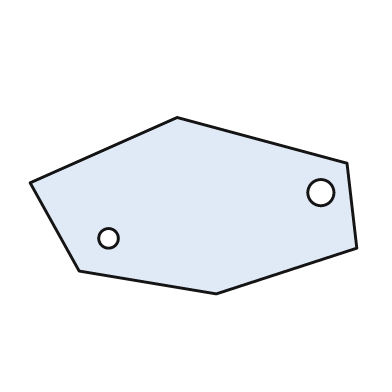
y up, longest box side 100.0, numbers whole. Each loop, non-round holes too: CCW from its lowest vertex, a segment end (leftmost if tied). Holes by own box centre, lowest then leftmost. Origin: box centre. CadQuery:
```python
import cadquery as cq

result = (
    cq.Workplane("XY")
    .moveTo(7.0, -27.0)
    .lineTo(50.0, -13.0)
    .lineTo(47.0, 13.0)
    .lineTo(-5.0, 27.0)
    .lineTo(-50.0, 7.0)
    .lineTo(-35.0, -20.0)
    .close()
    .moveTo(-26.0, -10.0)
    .circle(3.0)
    .moveTo(39.0, 4.0)
    .circle(4.0)
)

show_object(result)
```